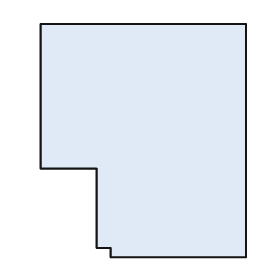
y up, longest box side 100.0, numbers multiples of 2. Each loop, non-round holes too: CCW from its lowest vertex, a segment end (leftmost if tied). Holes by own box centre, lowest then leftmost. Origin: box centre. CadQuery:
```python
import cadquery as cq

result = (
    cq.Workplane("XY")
    .moveTo(-14.0, -50.0)
    .lineTo(44.0, -50.0)
    .lineTo(44.0, 50.0)
    .lineTo(-44.0, 50.0)
    .lineTo(-44.0, -12.0)
    .lineTo(-20.0, -12.0)
    .lineTo(-20.0, -46.0)
    .lineTo(-14.0, -46.0)
    .close()
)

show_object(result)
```